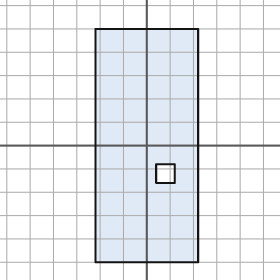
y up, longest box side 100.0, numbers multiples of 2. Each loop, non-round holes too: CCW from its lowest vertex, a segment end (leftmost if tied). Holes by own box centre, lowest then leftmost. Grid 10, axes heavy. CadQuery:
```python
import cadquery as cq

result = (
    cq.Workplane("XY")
    .moveTo(-22.0, -50.0)
    .lineTo(22.0, -50.0)
    .lineTo(22.0, 50.0)
    .lineTo(-22.0, 50.0)
    .close()
    .moveTo(4.0, -16.0)
    .lineTo(12.0, -16.0)
    .lineTo(12.0, -8.0)
    .lineTo(4.0, -8.0)
    .close()
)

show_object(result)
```